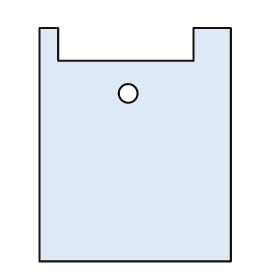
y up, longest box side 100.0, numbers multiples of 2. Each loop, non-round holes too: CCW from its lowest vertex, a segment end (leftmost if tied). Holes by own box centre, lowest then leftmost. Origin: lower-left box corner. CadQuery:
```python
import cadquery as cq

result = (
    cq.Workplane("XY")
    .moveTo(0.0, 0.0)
    .lineTo(82.0, 0.0)
    .lineTo(82.0, 100.0)
    .lineTo(66.0, 100.0)
    .lineTo(66.0, 86.0)
    .lineTo(8.0, 86.0)
    .lineTo(8.0, 100.0)
    .lineTo(0.0, 100.0)
    .close()
    .moveTo(38.0, 72.0)
    .circle(4.0)
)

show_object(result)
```